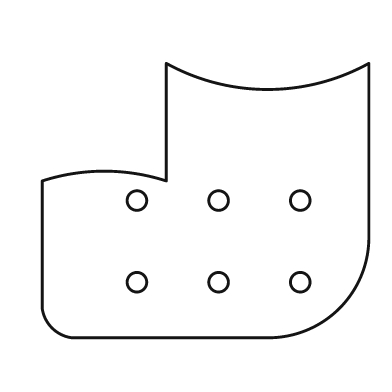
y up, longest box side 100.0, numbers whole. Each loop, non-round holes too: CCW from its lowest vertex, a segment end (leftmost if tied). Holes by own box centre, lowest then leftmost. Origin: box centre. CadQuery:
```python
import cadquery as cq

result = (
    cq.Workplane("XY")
    .moveTo(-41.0, -42.0)
    .lineTo(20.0, -42.0)
    .threePointArc((41.0, -33.0), (50.0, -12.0))
    .lineTo(50.0, 42.0)
    .threePointArc((19.0, 34.0), (-12.0, 42.0))
    .lineTo(-12.0, 6.0)
    .threePointArc((-31.0, 9.0), (-50.0, 6.0))
    .lineTo(-50.0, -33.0)
    .threePointArc((-47.0, -39.0), (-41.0, -42.0))
    .close()
    .moveTo(-21.0, -25.0)
    .circle(3.0)
    .moveTo(4.0, -25.0)
    .circle(3.0)
    .moveTo(29.0, -25.0)
    .circle(3.0)
    .moveTo(-21.0, 0.0)
    .circle(3.0)
    .moveTo(4.0, 0.0)
    .circle(3.0)
    .moveTo(29.0, 0.0)
    .circle(3.0)
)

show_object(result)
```